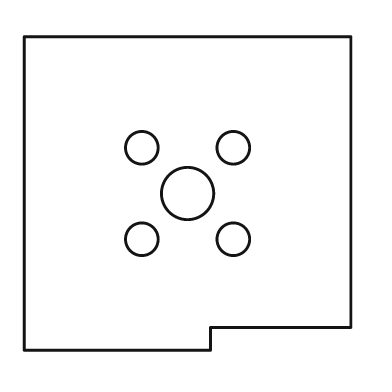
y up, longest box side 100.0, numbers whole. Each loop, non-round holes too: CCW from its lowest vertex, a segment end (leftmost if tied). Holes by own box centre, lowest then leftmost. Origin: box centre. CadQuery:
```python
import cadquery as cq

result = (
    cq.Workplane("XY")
    .moveTo(-50.0, -48.0)
    .lineTo(7.0, -48.0)
    .lineTo(7.0, -41.0)
    .lineTo(50.0, -41.0)
    .lineTo(50.0, 48.0)
    .lineTo(-50.0, 48.0)
    .close()
    .moveTo(-14.0, -14.0)
    .circle(5.0)
    .moveTo(14.0, -14.0)
    .circle(5.0)
    .moveTo(0.0, 0.0)
    .circle(8.0)
    .moveTo(-14.0, 14.0)
    .circle(5.0)
    .moveTo(14.0, 14.0)
    .circle(5.0)
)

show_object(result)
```